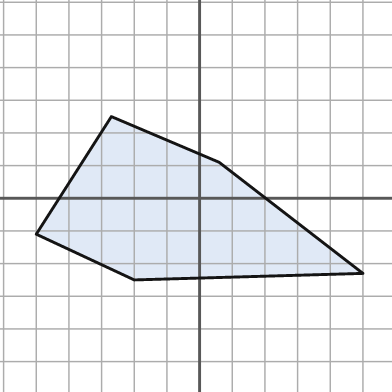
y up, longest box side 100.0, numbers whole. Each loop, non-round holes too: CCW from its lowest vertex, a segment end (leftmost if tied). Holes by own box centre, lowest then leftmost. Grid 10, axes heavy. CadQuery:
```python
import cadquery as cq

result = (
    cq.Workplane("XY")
    .moveTo(-20.0, -25.0)
    .lineTo(50.0, -23.0)
    .lineTo(6.0, 11.0)
    .lineTo(-27.0, 25.0)
    .lineTo(-50.0, -11.0)
    .close()
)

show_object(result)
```